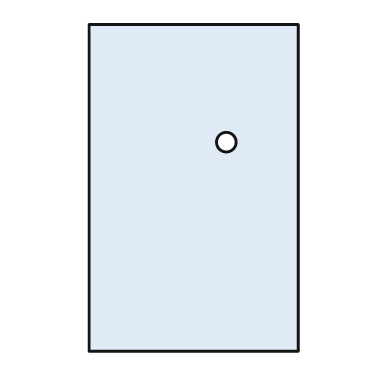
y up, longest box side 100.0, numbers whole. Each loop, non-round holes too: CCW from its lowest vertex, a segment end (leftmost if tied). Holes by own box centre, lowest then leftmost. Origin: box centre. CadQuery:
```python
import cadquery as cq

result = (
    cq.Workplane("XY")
    .moveTo(-32.0, -50.0)
    .lineTo(32.0, -50.0)
    .lineTo(32.0, 50.0)
    .lineTo(-32.0, 50.0)
    .close()
    .moveTo(10.0, 14.0)
    .circle(3.0)
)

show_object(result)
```